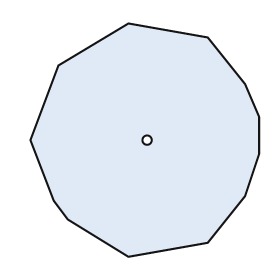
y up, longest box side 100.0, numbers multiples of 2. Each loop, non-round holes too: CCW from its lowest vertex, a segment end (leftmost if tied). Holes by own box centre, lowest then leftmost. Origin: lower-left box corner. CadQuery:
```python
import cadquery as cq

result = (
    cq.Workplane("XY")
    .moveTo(42.0, 0.0)
    .lineTo(76.0, 6.0)
    .lineTo(92.0, 26.0)
    .lineTo(98.0, 44.0)
    .lineTo(98.0, 60.0)
    .lineTo(92.0, 74.0)
    .lineTo(76.0, 94.0)
    .lineTo(42.0, 100.0)
    .lineTo(12.0, 82.0)
    .lineTo(0.0, 50.0)
    .lineTo(10.0, 24.0)
    .lineTo(16.0, 16.0)
    .close()
    .moveTo(50.0, 50.0)
    .circle(2.0)
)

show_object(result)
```